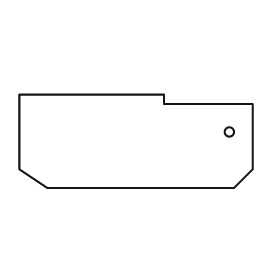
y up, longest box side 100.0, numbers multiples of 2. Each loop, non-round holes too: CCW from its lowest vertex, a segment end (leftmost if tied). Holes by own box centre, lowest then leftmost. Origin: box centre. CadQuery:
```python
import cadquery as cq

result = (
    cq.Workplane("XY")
    .moveTo(-38.0, -20.0)
    .lineTo(42.0, -20.0)
    .lineTo(50.0, -12.0)
    .lineTo(50.0, 16.0)
    .lineTo(12.0, 16.0)
    .lineTo(12.0, 20.0)
    .lineTo(-50.0, 20.0)
    .lineTo(-50.0, -12.0)
    .close()
    .moveTo(40.0, 4.0)
    .circle(2.0)
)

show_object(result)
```